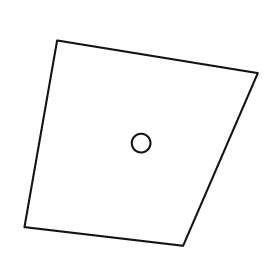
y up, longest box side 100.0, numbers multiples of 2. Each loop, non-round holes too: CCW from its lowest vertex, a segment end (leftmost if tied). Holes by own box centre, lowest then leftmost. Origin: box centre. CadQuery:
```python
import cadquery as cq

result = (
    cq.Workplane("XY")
    .moveTo(18.0, -44.0)
    .lineTo(50.0, 30.0)
    .lineTo(-36.0, 44.0)
    .lineTo(-50.0, -36.0)
    .close()
    .moveTo(0.0, 0.0)
    .circle(4.0)
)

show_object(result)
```